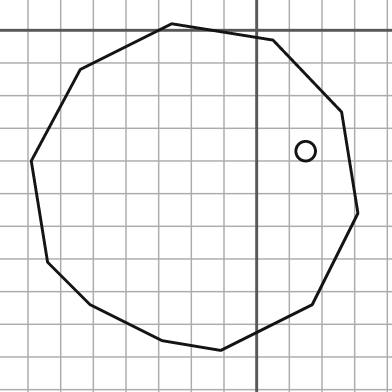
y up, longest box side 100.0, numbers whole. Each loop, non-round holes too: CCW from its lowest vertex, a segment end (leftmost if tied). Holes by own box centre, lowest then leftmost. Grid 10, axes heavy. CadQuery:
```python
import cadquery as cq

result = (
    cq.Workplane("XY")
    .moveTo(-11.0, -98.0)
    .lineTo(17.0, -84.0)
    .lineTo(31.0, -56.0)
    .lineTo(26.0, -25.0)
    .lineTo(5.0, -3.0)
    .lineTo(-26.0, 2.0)
    .lineTo(-54.0, -12.0)
    .lineTo(-69.0, -40.0)
    .lineTo(-64.0, -71.0)
    .lineTo(-51.0, -84.0)
    .lineTo(-29.0, -95.0)
    .close()
    .moveTo(15.0, -37.0)
    .circle(3.0)
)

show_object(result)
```